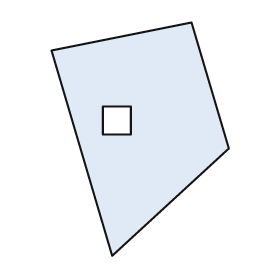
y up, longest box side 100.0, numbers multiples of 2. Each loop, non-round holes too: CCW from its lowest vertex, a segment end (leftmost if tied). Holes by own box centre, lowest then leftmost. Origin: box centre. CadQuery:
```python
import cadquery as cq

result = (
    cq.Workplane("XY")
    .moveTo(-12.0, -50.0)
    .lineTo(38.0, -4.0)
    .lineTo(22.0, 50.0)
    .lineTo(-38.0, 38.0)
    .close()
    .moveTo(-16.0, 2.0)
    .lineTo(-4.0, 2.0)
    .lineTo(-4.0, 14.0)
    .lineTo(-16.0, 14.0)
    .close()
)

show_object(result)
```